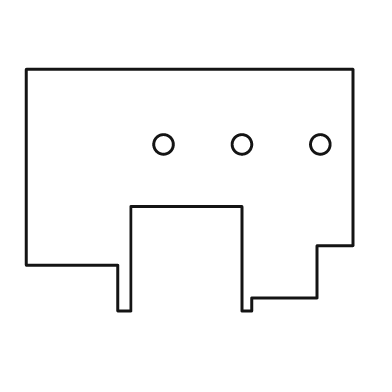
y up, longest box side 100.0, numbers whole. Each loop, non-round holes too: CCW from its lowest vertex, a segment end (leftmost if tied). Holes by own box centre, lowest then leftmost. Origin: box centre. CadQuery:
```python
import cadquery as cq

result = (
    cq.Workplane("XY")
    .moveTo(-22.0, -37.0)
    .lineTo(-18.0, -37.0)
    .lineTo(-18.0, -5.0)
    .lineTo(16.0, -5.0)
    .lineTo(16.0, -37.0)
    .lineTo(19.0, -37.0)
    .lineTo(19.0, -33.0)
    .lineTo(39.0, -33.0)
    .lineTo(39.0, -17.0)
    .lineTo(50.0, -17.0)
    .lineTo(50.0, 37.0)
    .lineTo(-50.0, 37.0)
    .lineTo(-50.0, -23.0)
    .lineTo(-22.0, -23.0)
    .close()
    .moveTo(-8.0, 14.0)
    .circle(3.0)
    .moveTo(16.0, 14.0)
    .circle(3.0)
    .moveTo(40.0, 14.0)
    .circle(3.0)
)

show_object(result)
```